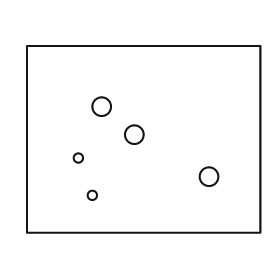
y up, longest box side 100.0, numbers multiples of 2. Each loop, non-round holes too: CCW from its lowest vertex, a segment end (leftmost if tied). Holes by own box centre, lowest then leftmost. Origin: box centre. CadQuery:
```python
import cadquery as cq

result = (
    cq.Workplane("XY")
    .moveTo(-50.0, -40.0)
    .lineTo(50.0, -40.0)
    .lineTo(50.0, 40.0)
    .lineTo(-50.0, 40.0)
    .close()
    .moveTo(-22.0, -24.0)
    .circle(2.0)
    .moveTo(28.0, -16.0)
    .circle(4.0)
    .moveTo(-28.0, -8.0)
    .circle(2.0)
    .moveTo(-4.0, 2.0)
    .circle(4.0)
    .moveTo(-18.0, 14.0)
    .circle(4.0)
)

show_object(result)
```